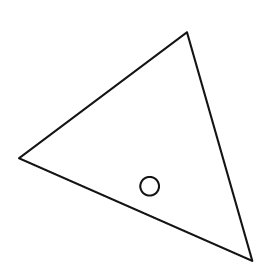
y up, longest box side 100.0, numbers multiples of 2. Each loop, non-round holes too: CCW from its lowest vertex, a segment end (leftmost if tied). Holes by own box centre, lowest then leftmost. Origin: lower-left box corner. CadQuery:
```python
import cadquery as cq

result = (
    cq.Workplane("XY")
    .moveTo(100.0, 0.0)
    .lineTo(72.0, 98.0)
    .lineTo(0.0, 44.0)
    .close()
    .moveTo(56.0, 32.0)
    .circle(4.0)
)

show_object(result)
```